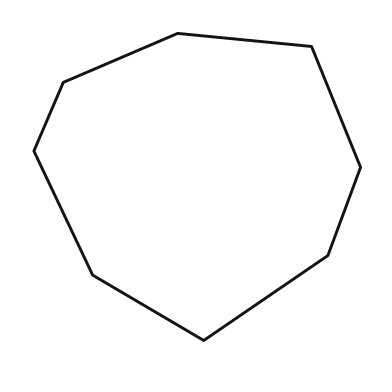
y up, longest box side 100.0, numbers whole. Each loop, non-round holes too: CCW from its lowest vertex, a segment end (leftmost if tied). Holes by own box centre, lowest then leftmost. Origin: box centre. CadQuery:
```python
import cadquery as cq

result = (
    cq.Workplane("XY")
    .moveTo(2.0, -47.0)
    .lineTo(40.0, -21.0)
    .lineTo(50.0, 6.0)
    .lineTo(35.0, 43.0)
    .lineTo(-6.0, 47.0)
    .lineTo(-41.0, 32.0)
    .lineTo(-50.0, 11.0)
    .lineTo(-32.0, -27.0)
    .close()
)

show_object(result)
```